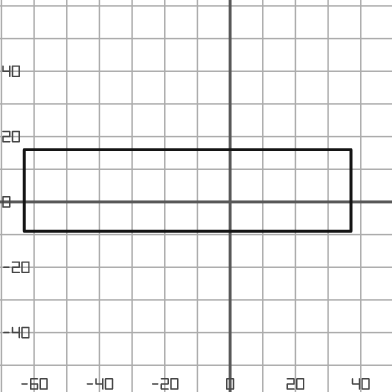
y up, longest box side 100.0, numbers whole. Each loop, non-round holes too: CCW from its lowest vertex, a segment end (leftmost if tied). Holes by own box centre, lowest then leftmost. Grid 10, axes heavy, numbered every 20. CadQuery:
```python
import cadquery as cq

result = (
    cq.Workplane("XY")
    .moveTo(-63.0, -9.0)
    .lineTo(37.0, -9.0)
    .lineTo(37.0, 16.0)
    .lineTo(-63.0, 16.0)
    .close()
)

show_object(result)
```